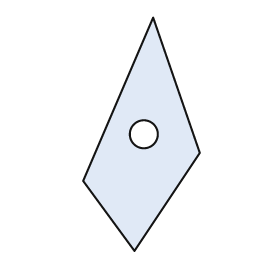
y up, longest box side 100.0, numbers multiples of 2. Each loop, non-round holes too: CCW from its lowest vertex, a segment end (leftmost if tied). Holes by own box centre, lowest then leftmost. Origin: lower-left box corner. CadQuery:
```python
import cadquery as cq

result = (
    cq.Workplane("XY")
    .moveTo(22.0, 0.0)
    .lineTo(50.0, 42.0)
    .lineTo(30.0, 100.0)
    .lineTo(0.0, 30.0)
    .close()
    .moveTo(26.0, 50.0)
    .circle(6.0)
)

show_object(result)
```